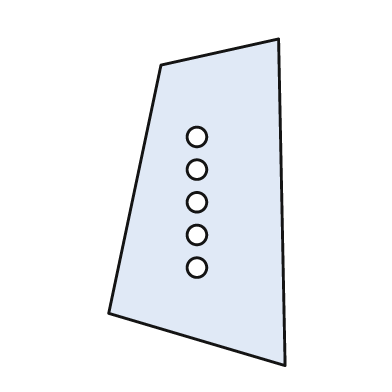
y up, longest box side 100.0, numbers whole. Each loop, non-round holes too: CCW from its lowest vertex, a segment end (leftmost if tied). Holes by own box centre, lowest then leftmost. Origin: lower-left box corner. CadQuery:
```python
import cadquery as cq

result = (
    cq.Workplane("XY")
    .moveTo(54.0, 0.0)
    .lineTo(52.0, 100.0)
    .lineTo(16.0, 92.0)
    .lineTo(0.0, 16.0)
    .close()
    .moveTo(27.0, 30.0)
    .circle(3.0)
    .moveTo(27.0, 40.0)
    .circle(3.0)
    .moveTo(27.0, 50.0)
    .circle(3.0)
    .moveTo(27.0, 60.0)
    .circle(3.0)
    .moveTo(27.0, 70.0)
    .circle(3.0)
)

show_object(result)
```